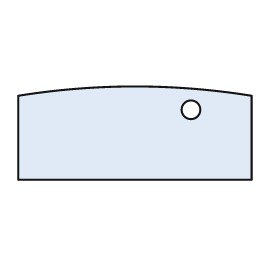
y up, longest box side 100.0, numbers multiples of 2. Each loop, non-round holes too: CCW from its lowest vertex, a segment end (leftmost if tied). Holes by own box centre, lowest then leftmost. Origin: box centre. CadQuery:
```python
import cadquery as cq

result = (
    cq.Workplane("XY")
    .moveTo(-50.0, -20.0)
    .lineTo(50.0, -20.0)
    .lineTo(50.0, 16.0)
    .threePointArc((0.0, 20.0), (-50.0, 16.0))
    .close()
    .moveTo(24.0, 10.0)
    .circle(4.0)
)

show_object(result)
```